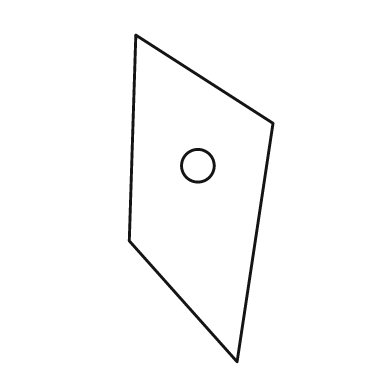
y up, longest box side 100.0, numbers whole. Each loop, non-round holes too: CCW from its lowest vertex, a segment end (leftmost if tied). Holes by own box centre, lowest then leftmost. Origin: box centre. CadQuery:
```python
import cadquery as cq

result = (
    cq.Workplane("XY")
    .moveTo(11.0, -50.0)
    .lineTo(22.0, 23.0)
    .lineTo(-20.0, 50.0)
    .lineTo(-22.0, -13.0)
    .close()
    .moveTo(-1.0, 10.0)
    .circle(5.0)
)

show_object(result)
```